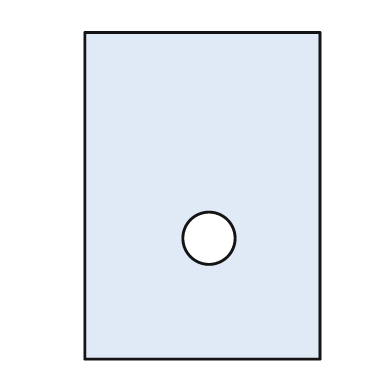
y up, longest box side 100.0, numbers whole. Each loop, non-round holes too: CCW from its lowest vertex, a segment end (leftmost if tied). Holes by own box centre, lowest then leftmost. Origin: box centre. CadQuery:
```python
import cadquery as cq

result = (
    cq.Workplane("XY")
    .moveTo(-36.0, -50.0)
    .lineTo(36.0, -50.0)
    .lineTo(36.0, 50.0)
    .lineTo(-36.0, 50.0)
    .close()
    .moveTo(2.0, -13.0)
    .circle(8.0)
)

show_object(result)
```